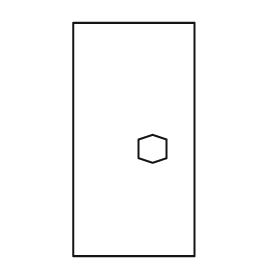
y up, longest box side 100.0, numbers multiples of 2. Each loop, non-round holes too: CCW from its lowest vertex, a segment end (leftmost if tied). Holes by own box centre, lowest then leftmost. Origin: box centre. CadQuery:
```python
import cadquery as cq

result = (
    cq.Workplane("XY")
    .moveTo(-26.0, -50.0)
    .lineTo(26.0, -50.0)
    .lineTo(26.0, 50.0)
    .lineTo(-26.0, 50.0)
    .close()
    .moveTo(8.0, -10.0)
    .lineTo(14.0, -8.0)
    .lineTo(14.0, 0.0)
    .lineTo(8.0, 2.0)
    .lineTo(2.0, 0.0)
    .lineTo(2.0, -8.0)
    .close()
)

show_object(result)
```